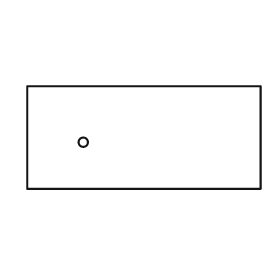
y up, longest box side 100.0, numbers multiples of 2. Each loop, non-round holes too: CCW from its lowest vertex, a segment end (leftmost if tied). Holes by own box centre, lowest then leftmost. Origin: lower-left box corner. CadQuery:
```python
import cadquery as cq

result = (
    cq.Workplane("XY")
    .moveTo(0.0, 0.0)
    .lineTo(100.0, 0.0)
    .lineTo(100.0, 44.0)
    .lineTo(0.0, 44.0)
    .close()
    .moveTo(24.0, 20.0)
    .circle(2.0)
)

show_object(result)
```